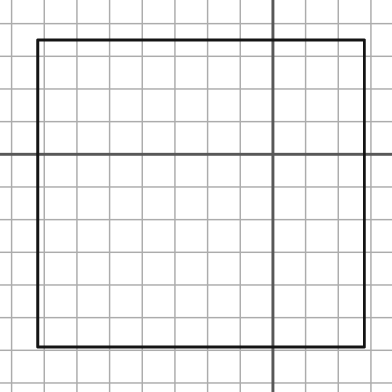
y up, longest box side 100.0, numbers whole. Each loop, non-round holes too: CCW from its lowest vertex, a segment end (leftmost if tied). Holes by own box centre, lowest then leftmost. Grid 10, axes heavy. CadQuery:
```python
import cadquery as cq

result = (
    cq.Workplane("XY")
    .moveTo(-72.0, -59.0)
    .lineTo(28.0, -59.0)
    .lineTo(28.0, 35.0)
    .lineTo(-72.0, 35.0)
    .close()
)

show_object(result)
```